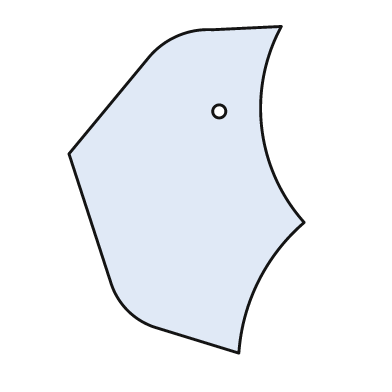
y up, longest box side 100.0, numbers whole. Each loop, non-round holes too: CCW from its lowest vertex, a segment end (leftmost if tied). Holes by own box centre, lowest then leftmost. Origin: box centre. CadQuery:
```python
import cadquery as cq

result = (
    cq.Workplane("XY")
    .moveTo(16.0, -50.0)
    .threePointArc((22.0, -28.0), (36.0, -10.0))
    .threePointArc((23.0, 19.0), (29.0, 50.0))
    .lineTo(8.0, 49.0)
    .threePointArc((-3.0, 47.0), (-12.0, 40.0))
    .lineTo(-36.0, 11.0)
    .lineTo(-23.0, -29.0)
    .threePointArc((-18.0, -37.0), (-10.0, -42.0))
    .close()
    .moveTo(10.0, 24.0)
    .circle(2.0)
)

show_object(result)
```